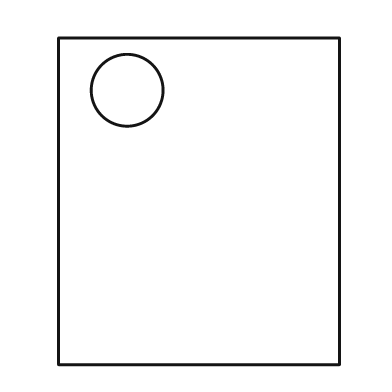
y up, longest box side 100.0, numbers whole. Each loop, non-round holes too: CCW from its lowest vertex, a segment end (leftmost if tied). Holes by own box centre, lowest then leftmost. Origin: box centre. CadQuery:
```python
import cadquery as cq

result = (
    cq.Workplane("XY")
    .moveTo(-43.0, -50.0)
    .lineTo(43.0, -50.0)
    .lineTo(43.0, 50.0)
    .lineTo(-43.0, 50.0)
    .close()
    .moveTo(-22.0, 34.0)
    .circle(11.0)
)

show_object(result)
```